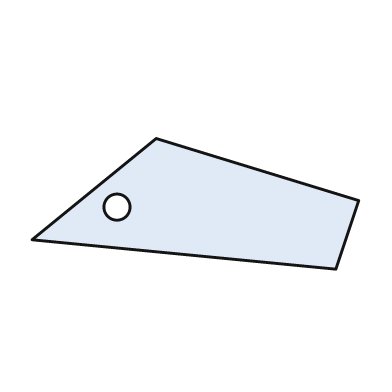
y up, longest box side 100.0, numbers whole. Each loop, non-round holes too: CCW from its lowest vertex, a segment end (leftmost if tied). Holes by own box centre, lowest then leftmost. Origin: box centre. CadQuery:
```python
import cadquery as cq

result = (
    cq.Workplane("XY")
    .moveTo(43.0, -20.0)
    .lineTo(50.0, 1.0)
    .lineTo(-12.0, 20.0)
    .lineTo(-50.0, -11.0)
    .close()
    .moveTo(-24.0, -1.0)
    .circle(4.0)
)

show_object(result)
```